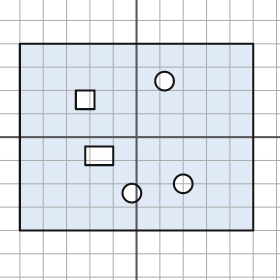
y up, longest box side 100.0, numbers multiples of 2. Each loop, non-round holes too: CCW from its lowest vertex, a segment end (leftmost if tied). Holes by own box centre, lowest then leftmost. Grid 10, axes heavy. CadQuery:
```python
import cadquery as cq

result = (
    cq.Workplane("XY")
    .moveTo(-50.0, -40.0)
    .lineTo(50.0, -40.0)
    .lineTo(50.0, 40.0)
    .lineTo(-50.0, 40.0)
    .close()
    .moveTo(-2.0, -24.0)
    .circle(4.0)
    .moveTo(20.0, -20.0)
    .circle(4.0)
    .moveTo(-22.0, -12.0)
    .lineTo(-10.0, -12.0)
    .lineTo(-10.0, -4.0)
    .lineTo(-22.0, -4.0)
    .close()
    .moveTo(-26.0, 12.0)
    .lineTo(-18.0, 12.0)
    .lineTo(-18.0, 20.0)
    .lineTo(-26.0, 20.0)
    .close()
    .moveTo(12.0, 24.0)
    .circle(4.0)
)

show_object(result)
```